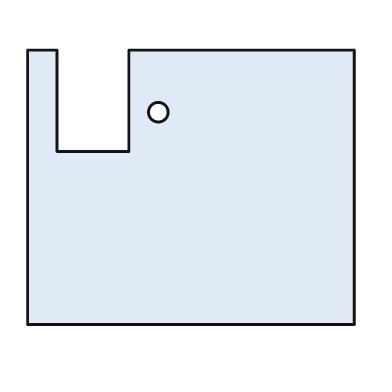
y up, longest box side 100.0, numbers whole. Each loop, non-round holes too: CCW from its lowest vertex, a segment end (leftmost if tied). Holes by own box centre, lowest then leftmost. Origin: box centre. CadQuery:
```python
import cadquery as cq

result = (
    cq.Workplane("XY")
    .moveTo(-50.0, -42.0)
    .lineTo(50.0, -42.0)
    .lineTo(50.0, 42.0)
    .lineTo(-19.0, 42.0)
    .lineTo(-19.0, 11.0)
    .lineTo(-41.0, 11.0)
    .lineTo(-41.0, 42.0)
    .lineTo(-50.0, 42.0)
    .close()
    .moveTo(-10.0, 23.0)
    .circle(3.0)
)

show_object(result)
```